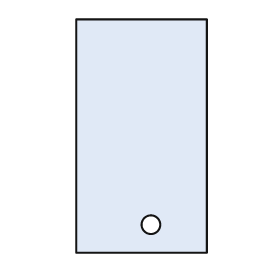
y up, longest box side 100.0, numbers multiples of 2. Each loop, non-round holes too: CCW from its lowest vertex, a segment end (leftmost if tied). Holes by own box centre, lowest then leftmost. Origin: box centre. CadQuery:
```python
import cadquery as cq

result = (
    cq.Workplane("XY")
    .moveTo(-28.0, -50.0)
    .lineTo(28.0, -50.0)
    .lineTo(28.0, 50.0)
    .lineTo(-28.0, 50.0)
    .close()
    .moveTo(4.0, -38.0)
    .circle(4.0)
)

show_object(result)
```